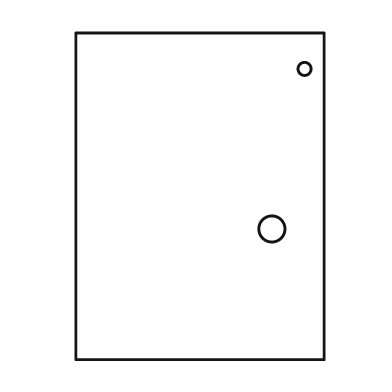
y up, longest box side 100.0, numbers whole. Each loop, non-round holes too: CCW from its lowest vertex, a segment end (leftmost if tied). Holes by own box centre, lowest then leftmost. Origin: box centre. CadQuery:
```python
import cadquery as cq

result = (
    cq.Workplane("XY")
    .moveTo(-38.0, -50.0)
    .lineTo(38.0, -50.0)
    .lineTo(38.0, 50.0)
    .lineTo(-38.0, 50.0)
    .close()
    .moveTo(22.0, -10.0)
    .circle(4.0)
    .moveTo(32.0, 39.0)
    .circle(2.0)
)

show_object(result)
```